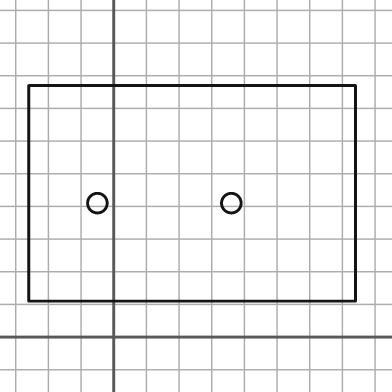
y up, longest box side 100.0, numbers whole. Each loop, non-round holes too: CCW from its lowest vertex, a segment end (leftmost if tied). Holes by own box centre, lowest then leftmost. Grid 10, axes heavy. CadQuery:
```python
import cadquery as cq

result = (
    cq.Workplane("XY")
    .moveTo(-26.0, 11.0)
    .lineTo(74.0, 11.0)
    .lineTo(74.0, 77.0)
    .lineTo(-26.0, 77.0)
    .close()
    .moveTo(-5.0, 41.0)
    .circle(3.0)
    .moveTo(36.0, 41.0)
    .circle(3.0)
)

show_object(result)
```